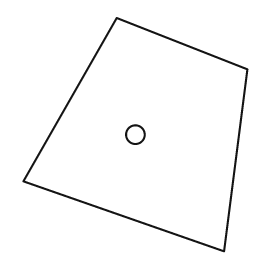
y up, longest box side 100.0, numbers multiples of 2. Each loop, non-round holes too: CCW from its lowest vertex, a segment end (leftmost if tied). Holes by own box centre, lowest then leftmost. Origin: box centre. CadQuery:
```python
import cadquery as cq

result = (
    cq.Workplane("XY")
    .moveTo(38.0, -50.0)
    .lineTo(48.0, 28.0)
    .lineTo(-8.0, 50.0)
    .lineTo(-48.0, -20.0)
    .close()
    .moveTo(0.0, 0.0)
    .circle(4.0)
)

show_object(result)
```